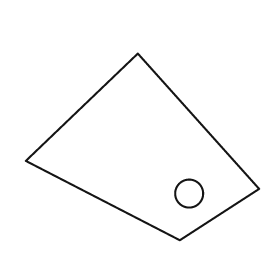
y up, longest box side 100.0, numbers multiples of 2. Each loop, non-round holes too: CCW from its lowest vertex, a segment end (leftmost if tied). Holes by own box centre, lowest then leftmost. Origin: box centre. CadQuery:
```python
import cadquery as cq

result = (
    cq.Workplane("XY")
    .moveTo(16.0, -40.0)
    .lineTo(50.0, -18.0)
    .lineTo(-2.0, 40.0)
    .lineTo(-50.0, -6.0)
    .close()
    .moveTo(20.0, -20.0)
    .circle(6.0)
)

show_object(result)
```